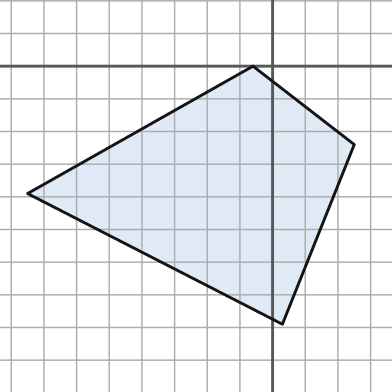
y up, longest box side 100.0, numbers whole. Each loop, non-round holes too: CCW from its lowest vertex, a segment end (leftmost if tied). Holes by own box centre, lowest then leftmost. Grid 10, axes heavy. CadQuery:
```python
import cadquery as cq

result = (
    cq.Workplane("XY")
    .moveTo(3.0, -79.0)
    .lineTo(25.0, -24.0)
    .lineTo(-6.0, 0.0)
    .lineTo(-75.0, -39.0)
    .close()
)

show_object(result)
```